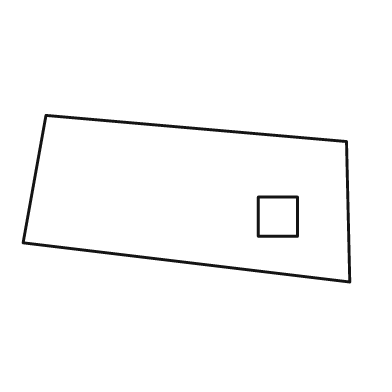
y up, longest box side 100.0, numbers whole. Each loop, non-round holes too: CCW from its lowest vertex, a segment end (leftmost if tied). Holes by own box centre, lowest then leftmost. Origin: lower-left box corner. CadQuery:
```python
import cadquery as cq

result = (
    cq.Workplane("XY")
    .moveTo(100.0, 0.0)
    .lineTo(99.0, 43.0)
    .lineTo(7.0, 51.0)
    .lineTo(0.0, 12.0)
    .close()
    .moveTo(72.0, 14.0)
    .lineTo(84.0, 14.0)
    .lineTo(84.0, 26.0)
    .lineTo(72.0, 26.0)
    .close()
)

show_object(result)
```